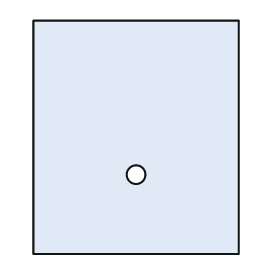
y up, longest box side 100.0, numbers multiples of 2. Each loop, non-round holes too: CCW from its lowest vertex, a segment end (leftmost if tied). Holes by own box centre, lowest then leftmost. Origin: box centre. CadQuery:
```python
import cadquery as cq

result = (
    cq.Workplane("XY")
    .moveTo(-44.0, -50.0)
    .lineTo(44.0, -50.0)
    .lineTo(44.0, 50.0)
    .lineTo(-44.0, 50.0)
    .close()
    .moveTo(0.0, -16.0)
    .circle(4.0)
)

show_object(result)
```